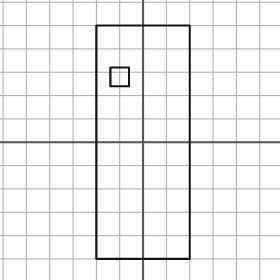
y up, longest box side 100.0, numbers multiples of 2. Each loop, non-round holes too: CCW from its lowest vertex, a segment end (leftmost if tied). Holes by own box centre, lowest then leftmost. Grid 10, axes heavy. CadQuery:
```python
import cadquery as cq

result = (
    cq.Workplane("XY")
    .moveTo(-20.0, -50.0)
    .lineTo(20.0, -50.0)
    .lineTo(20.0, 50.0)
    .lineTo(-20.0, 50.0)
    .close()
    .moveTo(-14.0, 24.0)
    .lineTo(-6.0, 24.0)
    .lineTo(-6.0, 32.0)
    .lineTo(-14.0, 32.0)
    .close()
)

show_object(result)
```